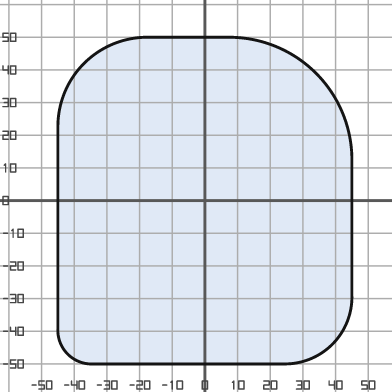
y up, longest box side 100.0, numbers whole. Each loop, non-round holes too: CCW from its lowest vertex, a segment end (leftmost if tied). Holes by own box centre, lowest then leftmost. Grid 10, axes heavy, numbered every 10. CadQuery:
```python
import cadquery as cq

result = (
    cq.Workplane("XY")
    .moveTo(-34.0, -50.0)
    .lineTo(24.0, -50.0)
    .threePointArc((39.0, -44.0), (45.0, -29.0))
    .lineTo(45.0, 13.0)
    .threePointArc((34.0, 39.0), (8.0, 50.0))
    .lineTo(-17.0, 50.0)
    .threePointArc((-37.0, 42.0), (-45.0, 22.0))
    .lineTo(-45.0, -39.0)
    .threePointArc((-42.0, -47.0), (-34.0, -50.0))
    .close()
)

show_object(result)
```